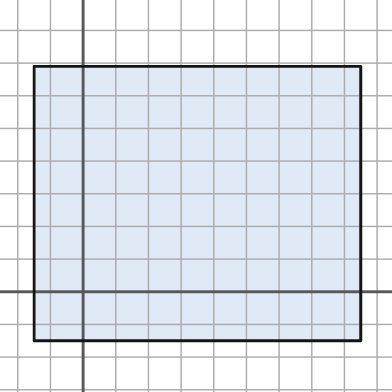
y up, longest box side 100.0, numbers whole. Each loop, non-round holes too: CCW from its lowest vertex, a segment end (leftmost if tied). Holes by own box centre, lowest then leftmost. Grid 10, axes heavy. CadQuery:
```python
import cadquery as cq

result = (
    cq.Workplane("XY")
    .moveTo(-15.0, -15.0)
    .lineTo(85.0, -15.0)
    .lineTo(85.0, 69.0)
    .lineTo(-15.0, 69.0)
    .close()
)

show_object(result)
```